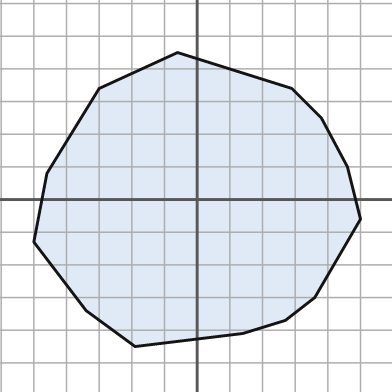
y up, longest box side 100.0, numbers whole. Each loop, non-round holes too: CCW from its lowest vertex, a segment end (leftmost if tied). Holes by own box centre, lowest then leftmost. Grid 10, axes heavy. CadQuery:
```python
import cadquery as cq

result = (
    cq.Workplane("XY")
    .moveTo(-19.0, -45.0)
    .lineTo(14.0, -41.0)
    .lineTo(27.0, -37.0)
    .lineTo(36.0, -30.0)
    .lineTo(50.0, -6.0)
    .lineTo(46.0, 10.0)
    .lineTo(38.0, 25.0)
    .lineTo(29.0, 34.0)
    .lineTo(-6.0, 45.0)
    .lineTo(-30.0, 34.0)
    .lineTo(-46.0, 8.0)
    .lineTo(-50.0, -13.0)
    .lineTo(-34.0, -34.0)
    .close()
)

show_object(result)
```